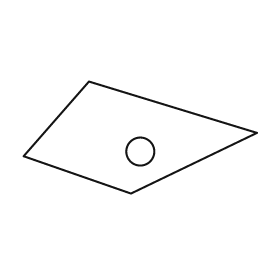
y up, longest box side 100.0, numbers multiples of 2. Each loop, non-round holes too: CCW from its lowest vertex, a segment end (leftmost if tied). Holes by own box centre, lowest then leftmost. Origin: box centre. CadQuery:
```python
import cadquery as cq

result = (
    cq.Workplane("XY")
    .moveTo(-4.0, -24.0)
    .lineTo(50.0, 2.0)
    .lineTo(-22.0, 24.0)
    .lineTo(-50.0, -8.0)
    .close()
    .moveTo(0.0, -6.0)
    .circle(6.0)
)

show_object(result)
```